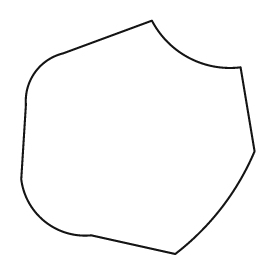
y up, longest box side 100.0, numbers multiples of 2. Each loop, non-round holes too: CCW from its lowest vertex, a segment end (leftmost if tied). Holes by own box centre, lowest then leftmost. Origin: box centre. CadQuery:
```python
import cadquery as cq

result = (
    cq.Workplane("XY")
    .moveTo(16.0, -50.0)
    .threePointArc((36.0, -30.0), (50.0, -6.0))
    .lineTo(44.0, 30.0)
    .threePointArc((22.0, 34.0), (6.0, 50.0))
    .lineTo(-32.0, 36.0)
    .threePointArc((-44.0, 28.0), (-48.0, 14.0))
    .lineTo(-50.0, -18.0)
    .threePointArc((-40.0, -36.0), (-20.0, -42.0))
    .close()
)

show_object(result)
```